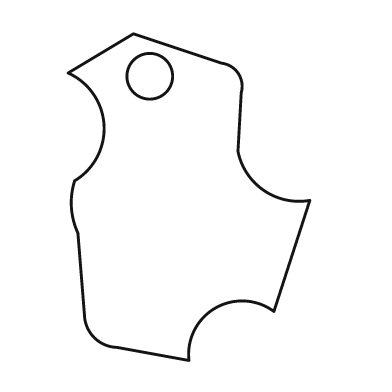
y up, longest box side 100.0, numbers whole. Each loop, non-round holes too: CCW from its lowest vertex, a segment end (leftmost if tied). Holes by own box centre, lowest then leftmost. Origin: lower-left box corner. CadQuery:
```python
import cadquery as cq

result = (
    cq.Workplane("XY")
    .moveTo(37.0, 0.0)
    .threePointArc((45.0, 16.0), (63.0, 15.0))
    .lineTo(74.0, 49.0)
    .threePointArc((60.0, 52.0), (52.0, 64.0))
    .lineTo(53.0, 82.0)
    .threePointArc((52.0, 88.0), (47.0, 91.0))
    .lineTo(20.0, 100.0)
    .lineTo(0.0, 88.0)
    .threePointArc((11.0, 72.0), (2.0, 55.0))
    .threePointArc((1.0, 47.0), (3.0, 39.0))
    .lineTo(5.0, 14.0)
    .threePointArc((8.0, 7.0), (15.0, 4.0))
    .close()
    .moveTo(25.0, 87.0)
    .circle(7.0)
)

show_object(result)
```